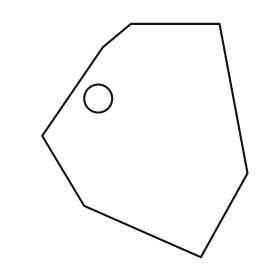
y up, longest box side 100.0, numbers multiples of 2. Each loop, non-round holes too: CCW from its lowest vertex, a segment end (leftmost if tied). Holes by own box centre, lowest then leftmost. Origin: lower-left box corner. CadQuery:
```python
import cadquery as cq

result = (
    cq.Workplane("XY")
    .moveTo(68.0, 0.0)
    .lineTo(88.0, 36.0)
    .lineTo(76.0, 100.0)
    .lineTo(38.0, 100.0)
    .lineTo(26.0, 90.0)
    .lineTo(0.0, 52.0)
    .lineTo(18.0, 22.0)
    .close()
    .moveTo(24.0, 68.0)
    .circle(6.0)
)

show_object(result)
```